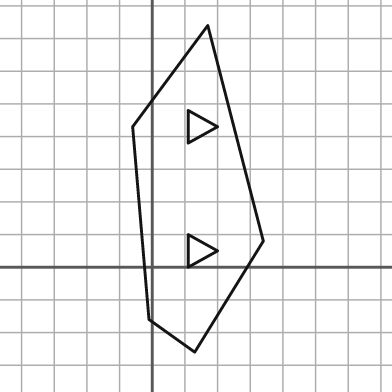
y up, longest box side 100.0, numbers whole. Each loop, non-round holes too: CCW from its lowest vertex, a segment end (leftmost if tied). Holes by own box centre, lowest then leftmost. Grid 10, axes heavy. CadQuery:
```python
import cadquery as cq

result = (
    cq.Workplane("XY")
    .moveTo(13.0, -26.0)
    .lineTo(34.0, 8.0)
    .lineTo(17.0, 74.0)
    .lineTo(-6.0, 43.0)
    .lineTo(-1.0, -16.0)
    .close()
    .moveTo(11.0, 0.0)
    .lineTo(20.0, 5.0)
    .lineTo(11.0, 10.0)
    .close()
    .moveTo(11.0, 38.0)
    .lineTo(20.0, 43.0)
    .lineTo(11.0, 48.0)
    .close()
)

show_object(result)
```